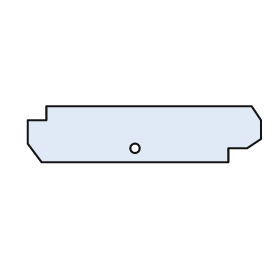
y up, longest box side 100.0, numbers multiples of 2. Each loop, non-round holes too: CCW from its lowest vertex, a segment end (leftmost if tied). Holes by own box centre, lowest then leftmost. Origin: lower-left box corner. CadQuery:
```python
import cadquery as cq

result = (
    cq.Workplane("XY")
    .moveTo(6.0, 0.0)
    .lineTo(86.0, 0.0)
    .lineTo(86.0, 6.0)
    .lineTo(94.0, 6.0)
    .lineTo(100.0, 10.0)
    .lineTo(100.0, 18.0)
    .lineTo(96.0, 24.0)
    .lineTo(8.0, 24.0)
    .lineTo(8.0, 18.0)
    .lineTo(0.0, 18.0)
    .lineTo(0.0, 8.0)
    .close()
    .moveTo(46.0, 6.0)
    .circle(2.0)
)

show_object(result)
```